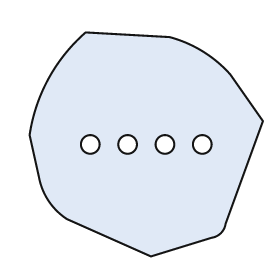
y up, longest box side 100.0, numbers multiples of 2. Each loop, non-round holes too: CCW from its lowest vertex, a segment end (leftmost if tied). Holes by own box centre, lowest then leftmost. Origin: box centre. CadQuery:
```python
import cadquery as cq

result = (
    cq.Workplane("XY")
    .moveTo(2.0, -48.0)
    .lineTo(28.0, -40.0)
    .threePointArc((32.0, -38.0), (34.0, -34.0))
    .lineTo(50.0, 10.0)
    .lineTo(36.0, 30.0)
    .threePointArc((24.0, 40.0), (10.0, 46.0))
    .lineTo(-26.0, 48.0)
    .threePointArc((-42.0, 28.0), (-50.0, 4.0))
    .lineTo(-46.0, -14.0)
    .threePointArc((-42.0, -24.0), (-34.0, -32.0))
    .close()
    .moveTo(-24.0, 0.0)
    .circle(4.0)
    .moveTo(-8.0, 0.0)
    .circle(4.0)
    .moveTo(8.0, 0.0)
    .circle(4.0)
    .moveTo(24.0, 0.0)
    .circle(4.0)
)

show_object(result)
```